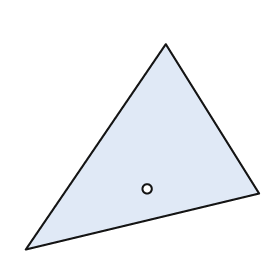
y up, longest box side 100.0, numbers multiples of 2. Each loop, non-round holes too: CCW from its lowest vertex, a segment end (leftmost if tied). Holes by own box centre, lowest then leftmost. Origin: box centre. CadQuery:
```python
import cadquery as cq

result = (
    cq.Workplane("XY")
    .moveTo(-50.0, -44.0)
    .lineTo(50.0, -20.0)
    .lineTo(10.0, 44.0)
    .close()
    .moveTo(2.0, -18.0)
    .circle(2.0)
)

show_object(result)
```